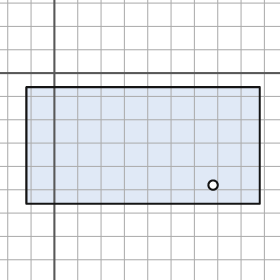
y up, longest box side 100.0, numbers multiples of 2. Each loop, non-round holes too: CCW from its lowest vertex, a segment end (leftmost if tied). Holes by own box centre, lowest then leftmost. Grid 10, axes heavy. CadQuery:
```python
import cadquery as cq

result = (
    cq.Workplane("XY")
    .moveTo(-12.0, -56.0)
    .lineTo(88.0, -56.0)
    .lineTo(88.0, -6.0)
    .lineTo(-12.0, -6.0)
    .close()
    .moveTo(68.0, -48.0)
    .circle(2.0)
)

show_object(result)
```